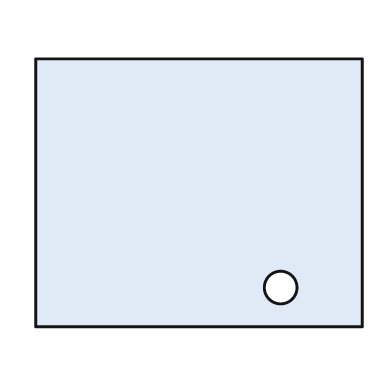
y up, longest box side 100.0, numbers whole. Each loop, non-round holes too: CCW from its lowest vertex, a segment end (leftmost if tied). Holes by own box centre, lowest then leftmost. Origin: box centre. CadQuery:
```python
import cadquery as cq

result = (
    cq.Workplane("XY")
    .moveTo(-50.0, -41.0)
    .lineTo(50.0, -41.0)
    .lineTo(50.0, 41.0)
    .lineTo(-50.0, 41.0)
    .close()
    .moveTo(25.0, -29.0)
    .circle(5.0)
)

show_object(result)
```